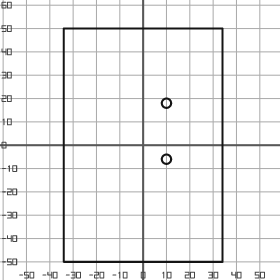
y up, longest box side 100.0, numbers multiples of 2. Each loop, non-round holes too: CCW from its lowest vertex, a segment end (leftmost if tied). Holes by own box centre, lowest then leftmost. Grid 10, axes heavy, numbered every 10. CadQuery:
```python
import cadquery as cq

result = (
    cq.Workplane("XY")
    .moveTo(-34.0, -50.0)
    .lineTo(34.0, -50.0)
    .lineTo(34.0, 50.0)
    .lineTo(-34.0, 50.0)
    .close()
    .moveTo(10.0, -6.0)
    .circle(2.0)
    .moveTo(10.0, 18.0)
    .circle(2.0)
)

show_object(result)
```